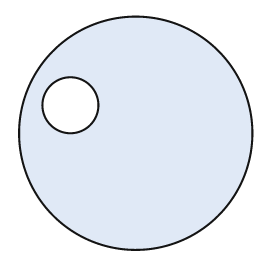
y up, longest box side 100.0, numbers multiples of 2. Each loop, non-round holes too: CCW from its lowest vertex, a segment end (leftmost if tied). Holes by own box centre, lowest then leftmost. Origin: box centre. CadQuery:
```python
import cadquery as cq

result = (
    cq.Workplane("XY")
    .moveTo(0.0, 0.0)
    .circle(50.0)
    .moveTo(-28.0, 12.0)
    .circle(12.0)
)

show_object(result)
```